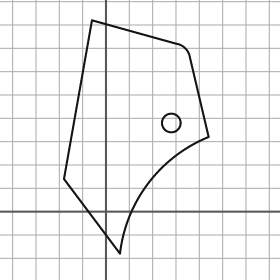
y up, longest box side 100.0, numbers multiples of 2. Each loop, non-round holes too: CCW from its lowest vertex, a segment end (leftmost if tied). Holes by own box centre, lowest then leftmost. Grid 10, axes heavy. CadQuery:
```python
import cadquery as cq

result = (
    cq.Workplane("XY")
    .moveTo(6.0, -18.0)
    .threePointArc((18.0, 12.0), (44.0, 32.0))
    .lineTo(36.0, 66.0)
    .threePointArc((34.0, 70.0), (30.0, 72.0))
    .lineTo(-6.0, 82.0)
    .lineTo(-18.0, 14.0)
    .close()
    .moveTo(28.0, 38.0)
    .circle(4.0)
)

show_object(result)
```